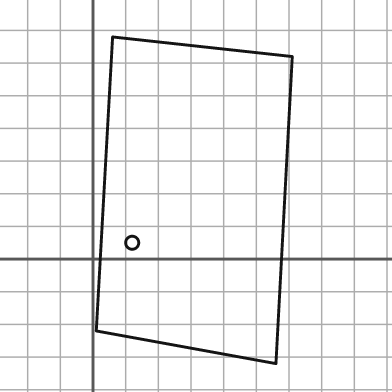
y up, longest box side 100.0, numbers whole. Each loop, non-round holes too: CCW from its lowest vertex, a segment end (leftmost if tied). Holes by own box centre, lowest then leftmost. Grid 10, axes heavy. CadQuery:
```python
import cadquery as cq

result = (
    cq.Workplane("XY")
    .moveTo(56.0, -32.0)
    .lineTo(61.0, 62.0)
    .lineTo(6.0, 68.0)
    .lineTo(1.0, -22.0)
    .close()
    .moveTo(12.0, 5.0)
    .circle(2.0)
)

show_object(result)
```